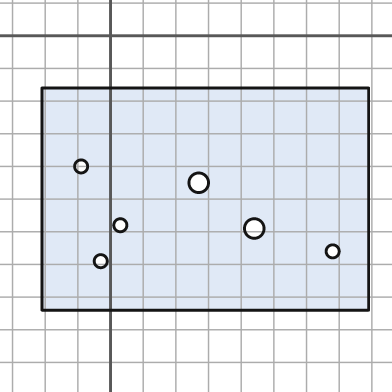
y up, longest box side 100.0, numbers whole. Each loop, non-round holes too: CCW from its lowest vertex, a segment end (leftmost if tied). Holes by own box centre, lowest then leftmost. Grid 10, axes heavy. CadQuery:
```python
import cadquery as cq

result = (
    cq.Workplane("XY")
    .moveTo(-21.0, -84.0)
    .lineTo(79.0, -84.0)
    .lineTo(79.0, -16.0)
    .lineTo(-21.0, -16.0)
    .close()
    .moveTo(-3.0, -69.0)
    .circle(2.0)
    .moveTo(68.0, -66.0)
    .circle(2.0)
    .moveTo(44.0, -59.0)
    .circle(3.0)
    .moveTo(3.0, -58.0)
    .circle(2.0)
    .moveTo(27.0, -45.0)
    .circle(3.0)
    .moveTo(-9.0, -40.0)
    .circle(2.0)
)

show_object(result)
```